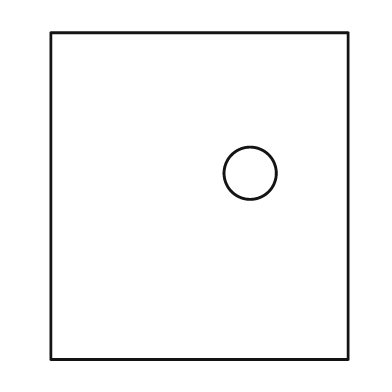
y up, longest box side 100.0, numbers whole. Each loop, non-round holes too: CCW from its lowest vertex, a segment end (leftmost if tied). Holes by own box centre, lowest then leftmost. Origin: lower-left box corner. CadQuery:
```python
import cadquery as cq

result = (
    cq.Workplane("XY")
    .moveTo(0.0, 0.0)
    .lineTo(91.0, 0.0)
    .lineTo(91.0, 100.0)
    .lineTo(0.0, 100.0)
    .close()
    .moveTo(61.0, 57.0)
    .circle(8.0)
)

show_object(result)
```